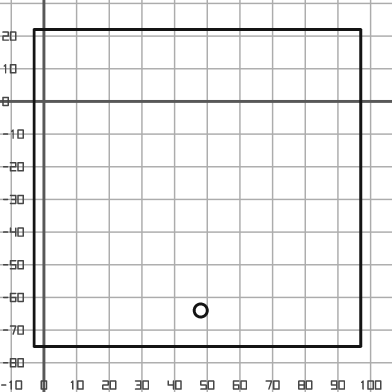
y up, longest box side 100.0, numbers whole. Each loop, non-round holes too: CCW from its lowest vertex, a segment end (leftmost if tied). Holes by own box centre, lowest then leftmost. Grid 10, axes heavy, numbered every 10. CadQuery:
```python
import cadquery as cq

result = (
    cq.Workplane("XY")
    .moveTo(-3.0, -75.0)
    .lineTo(97.0, -75.0)
    .lineTo(97.0, 22.0)
    .lineTo(-3.0, 22.0)
    .close()
    .moveTo(48.0, -64.0)
    .circle(2.0)
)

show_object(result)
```